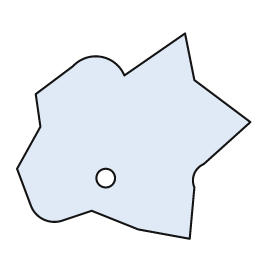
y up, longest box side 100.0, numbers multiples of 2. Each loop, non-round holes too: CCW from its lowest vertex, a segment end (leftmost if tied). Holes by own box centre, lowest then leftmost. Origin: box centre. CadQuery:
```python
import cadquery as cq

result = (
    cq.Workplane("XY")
    .moveTo(24.0, -44.0)
    .lineTo(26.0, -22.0)
    .threePointArc((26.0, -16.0), (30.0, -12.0))
    .lineTo(50.0, 6.0)
    .lineTo(26.0, 24.0)
    .lineTo(22.0, 44.0)
    .lineTo(-4.0, 26.0)
    .threePointArc((-14.0, 34.0), (-26.0, 30.0))
    .lineTo(-42.0, 18.0)
    .lineTo(-40.0, 4.0)
    .lineTo(-50.0, -14.0)
    .lineTo(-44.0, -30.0)
    .threePointArc((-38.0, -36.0), (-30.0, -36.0))
    .lineTo(-18.0, -32.0)
    .lineTo(2.0, -40.0)
    .close()
    .moveTo(-12.0, -18.0)
    .circle(4.0)
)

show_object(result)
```